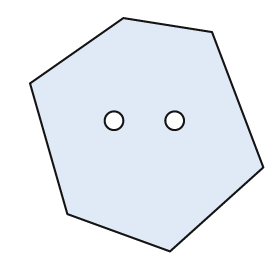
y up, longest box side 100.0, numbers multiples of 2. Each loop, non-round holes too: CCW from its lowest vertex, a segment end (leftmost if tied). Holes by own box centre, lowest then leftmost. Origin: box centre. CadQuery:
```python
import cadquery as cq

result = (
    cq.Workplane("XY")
    .moveTo(10.0, -50.0)
    .lineTo(50.0, -14.0)
    .lineTo(28.0, 44.0)
    .lineTo(-10.0, 50.0)
    .lineTo(-50.0, 22.0)
    .lineTo(-34.0, -34.0)
    .close()
    .moveTo(-14.0, 6.0)
    .circle(4.0)
    .moveTo(12.0, 6.0)
    .circle(4.0)
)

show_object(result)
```